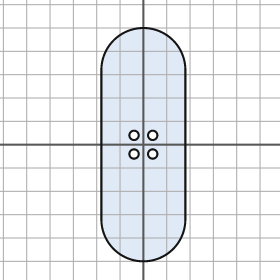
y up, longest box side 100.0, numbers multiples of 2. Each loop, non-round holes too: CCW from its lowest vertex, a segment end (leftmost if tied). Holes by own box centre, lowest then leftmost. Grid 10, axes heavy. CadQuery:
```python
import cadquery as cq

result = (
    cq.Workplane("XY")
    .moveTo(-18.0, -32.0)
    .threePointArc((0.0, -50.0), (18.0, -32.0))
    .lineTo(18.0, 32.0)
    .threePointArc((0.0, 50.0), (-18.0, 32.0))
    .close()
    .moveTo(-4.0, -4.0)
    .circle(2.0)
    .moveTo(4.0, -4.0)
    .circle(2.0)
    .moveTo(-4.0, 4.0)
    .circle(2.0)
    .moveTo(4.0, 4.0)
    .circle(2.0)
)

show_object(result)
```